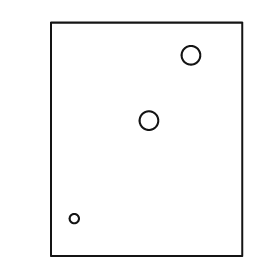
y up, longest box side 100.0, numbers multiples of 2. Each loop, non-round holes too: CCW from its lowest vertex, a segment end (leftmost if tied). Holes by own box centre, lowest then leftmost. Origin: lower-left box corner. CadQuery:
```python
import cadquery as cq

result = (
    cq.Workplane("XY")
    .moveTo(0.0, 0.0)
    .lineTo(82.0, 0.0)
    .lineTo(82.0, 100.0)
    .lineTo(0.0, 100.0)
    .close()
    .moveTo(10.0, 16.0)
    .circle(2.0)
    .moveTo(42.0, 58.0)
    .circle(4.0)
    .moveTo(60.0, 86.0)
    .circle(4.0)
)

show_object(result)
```